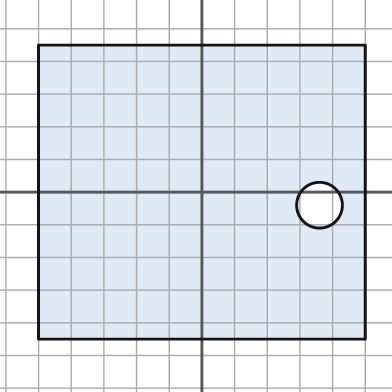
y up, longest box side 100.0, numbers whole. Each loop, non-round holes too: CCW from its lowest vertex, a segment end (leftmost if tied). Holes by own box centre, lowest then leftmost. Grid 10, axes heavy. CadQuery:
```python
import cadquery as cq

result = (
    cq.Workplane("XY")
    .moveTo(-50.0, -45.0)
    .lineTo(50.0, -45.0)
    .lineTo(50.0, 45.0)
    .lineTo(-50.0, 45.0)
    .close()
    .moveTo(36.0, -4.0)
    .circle(7.0)
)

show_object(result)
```